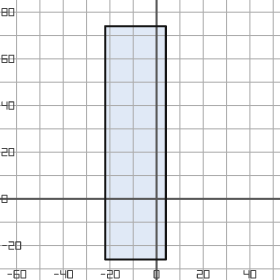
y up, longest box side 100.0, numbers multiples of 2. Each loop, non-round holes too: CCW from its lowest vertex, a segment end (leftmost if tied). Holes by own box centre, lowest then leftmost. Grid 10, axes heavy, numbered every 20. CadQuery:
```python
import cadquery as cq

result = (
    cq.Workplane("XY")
    .moveTo(-22.0, -26.0)
    .lineTo(4.0, -26.0)
    .lineTo(4.0, 74.0)
    .lineTo(-22.0, 74.0)
    .close()
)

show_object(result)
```